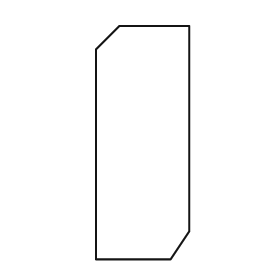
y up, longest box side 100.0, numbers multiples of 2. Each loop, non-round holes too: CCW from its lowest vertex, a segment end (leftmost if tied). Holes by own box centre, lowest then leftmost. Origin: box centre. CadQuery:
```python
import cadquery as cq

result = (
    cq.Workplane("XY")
    .moveTo(-20.0, -50.0)
    .lineTo(12.0, -50.0)
    .lineTo(20.0, -38.0)
    .lineTo(20.0, 50.0)
    .lineTo(-10.0, 50.0)
    .lineTo(-20.0, 40.0)
    .close()
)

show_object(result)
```